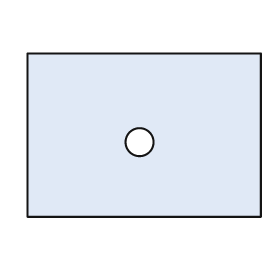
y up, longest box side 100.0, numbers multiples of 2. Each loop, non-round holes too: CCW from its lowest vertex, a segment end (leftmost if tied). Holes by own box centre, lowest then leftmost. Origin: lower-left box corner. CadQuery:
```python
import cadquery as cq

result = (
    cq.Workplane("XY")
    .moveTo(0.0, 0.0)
    .lineTo(100.0, 0.0)
    .lineTo(100.0, 70.0)
    .lineTo(0.0, 70.0)
    .close()
    .moveTo(48.0, 32.0)
    .circle(6.0)
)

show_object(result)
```